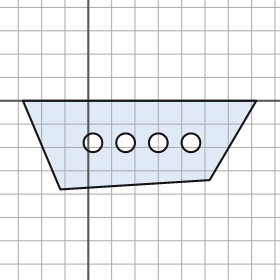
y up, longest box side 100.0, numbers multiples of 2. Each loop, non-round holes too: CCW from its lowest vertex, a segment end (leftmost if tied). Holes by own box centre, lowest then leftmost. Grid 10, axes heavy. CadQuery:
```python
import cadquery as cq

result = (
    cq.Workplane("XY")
    .moveTo(-12.0, -38.0)
    .lineTo(52.0, -34.0)
    .lineTo(72.0, 0.0)
    .lineTo(-28.0, 0.0)
    .close()
    .moveTo(2.0, -18.0)
    .circle(4.0)
    .moveTo(16.0, -18.0)
    .circle(4.0)
    .moveTo(30.0, -18.0)
    .circle(4.0)
    .moveTo(44.0, -18.0)
    .circle(4.0)
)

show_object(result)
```